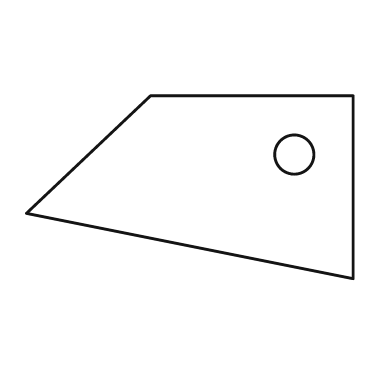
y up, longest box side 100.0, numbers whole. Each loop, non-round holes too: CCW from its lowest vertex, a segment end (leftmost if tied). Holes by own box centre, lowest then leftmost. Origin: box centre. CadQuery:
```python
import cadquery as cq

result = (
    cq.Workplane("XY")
    .moveTo(50.0, -28.0)
    .lineTo(50.0, 28.0)
    .lineTo(-12.0, 28.0)
    .lineTo(-50.0, -8.0)
    .close()
    .moveTo(32.0, 10.0)
    .circle(6.0)
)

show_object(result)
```